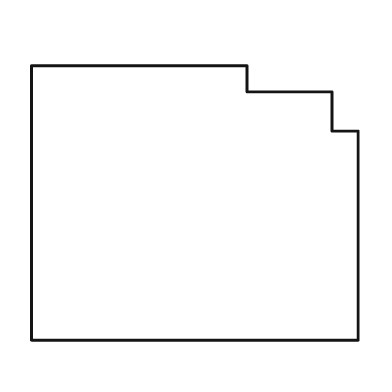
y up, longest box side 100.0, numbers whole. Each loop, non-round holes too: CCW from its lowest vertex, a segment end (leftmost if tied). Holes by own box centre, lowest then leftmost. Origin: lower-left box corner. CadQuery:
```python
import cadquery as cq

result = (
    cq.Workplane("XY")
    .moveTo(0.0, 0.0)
    .lineTo(100.0, 0.0)
    .lineTo(100.0, 64.0)
    .lineTo(92.0, 64.0)
    .lineTo(92.0, 76.0)
    .lineTo(66.0, 76.0)
    .lineTo(66.0, 84.0)
    .lineTo(0.0, 84.0)
    .close()
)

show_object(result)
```